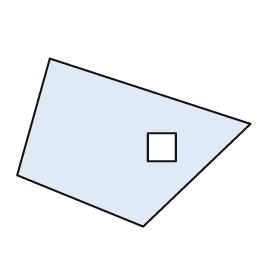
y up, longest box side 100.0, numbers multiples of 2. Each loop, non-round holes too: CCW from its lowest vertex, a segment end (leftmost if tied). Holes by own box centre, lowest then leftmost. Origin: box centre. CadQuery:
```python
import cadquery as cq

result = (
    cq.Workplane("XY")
    .moveTo(4.0, -36.0)
    .lineTo(50.0, 8.0)
    .lineTo(-36.0, 36.0)
    .lineTo(-50.0, -14.0)
    .close()
    .moveTo(6.0, -8.0)
    .lineTo(18.0, -8.0)
    .lineTo(18.0, 4.0)
    .lineTo(6.0, 4.0)
    .close()
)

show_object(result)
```